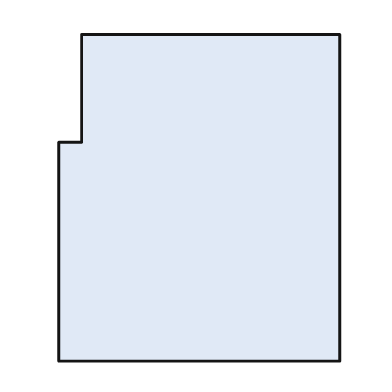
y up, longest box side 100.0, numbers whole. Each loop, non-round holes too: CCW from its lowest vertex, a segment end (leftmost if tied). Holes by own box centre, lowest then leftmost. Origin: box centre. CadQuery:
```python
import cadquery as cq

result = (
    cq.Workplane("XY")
    .moveTo(-43.0, -50.0)
    .lineTo(43.0, -50.0)
    .lineTo(43.0, 50.0)
    .lineTo(-36.0, 50.0)
    .lineTo(-36.0, 17.0)
    .lineTo(-43.0, 17.0)
    .close()
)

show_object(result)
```